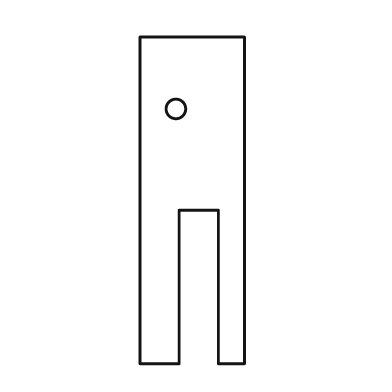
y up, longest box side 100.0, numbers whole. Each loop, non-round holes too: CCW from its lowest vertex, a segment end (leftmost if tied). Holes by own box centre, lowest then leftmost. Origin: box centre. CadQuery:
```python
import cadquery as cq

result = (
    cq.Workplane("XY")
    .moveTo(-16.0, -50.0)
    .lineTo(-4.0, -50.0)
    .lineTo(-4.0, -3.0)
    .lineTo(8.0, -3.0)
    .lineTo(8.0, -50.0)
    .lineTo(16.0, -50.0)
    .lineTo(16.0, 50.0)
    .lineTo(-16.0, 50.0)
    .close()
    .moveTo(-5.0, 28.0)
    .circle(3.0)
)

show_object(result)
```